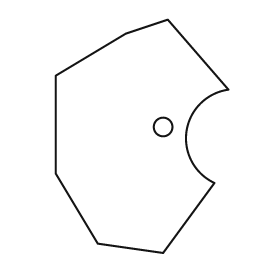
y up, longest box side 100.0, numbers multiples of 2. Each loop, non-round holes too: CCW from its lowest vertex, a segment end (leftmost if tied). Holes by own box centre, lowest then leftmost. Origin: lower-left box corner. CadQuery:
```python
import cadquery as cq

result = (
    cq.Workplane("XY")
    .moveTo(46.0, 0.0)
    .lineTo(68.0, 30.0)
    .threePointArc((56.0, 52.0), (74.0, 70.0))
    .lineTo(48.0, 100.0)
    .lineTo(30.0, 94.0)
    .lineTo(0.0, 76.0)
    .lineTo(0.0, 34.0)
    .lineTo(18.0, 4.0)
    .close()
    .moveTo(46.0, 54.0)
    .circle(4.0)
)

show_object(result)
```